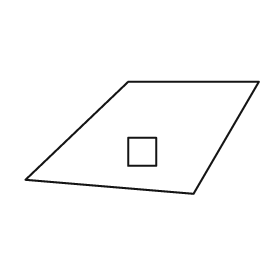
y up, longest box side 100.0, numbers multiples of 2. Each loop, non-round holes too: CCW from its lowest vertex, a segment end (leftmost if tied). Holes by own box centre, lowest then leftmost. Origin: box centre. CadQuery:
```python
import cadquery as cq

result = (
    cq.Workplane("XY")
    .moveTo(22.0, -24.0)
    .lineTo(50.0, 24.0)
    .lineTo(-6.0, 24.0)
    .lineTo(-50.0, -18.0)
    .close()
    .moveTo(-6.0, -12.0)
    .lineTo(6.0, -12.0)
    .lineTo(6.0, 0.0)
    .lineTo(-6.0, 0.0)
    .close()
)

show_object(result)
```